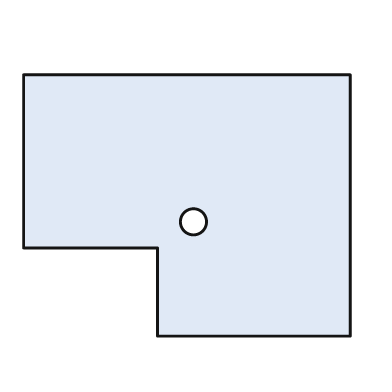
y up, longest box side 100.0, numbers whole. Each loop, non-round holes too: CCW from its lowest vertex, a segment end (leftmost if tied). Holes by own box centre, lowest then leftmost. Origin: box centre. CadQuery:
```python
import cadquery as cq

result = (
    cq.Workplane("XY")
    .moveTo(-9.0, -40.0)
    .lineTo(50.0, -40.0)
    .lineTo(50.0, 40.0)
    .lineTo(-50.0, 40.0)
    .lineTo(-50.0, -13.0)
    .lineTo(-9.0, -13.0)
    .close()
    .moveTo(2.0, -5.0)
    .circle(4.0)
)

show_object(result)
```